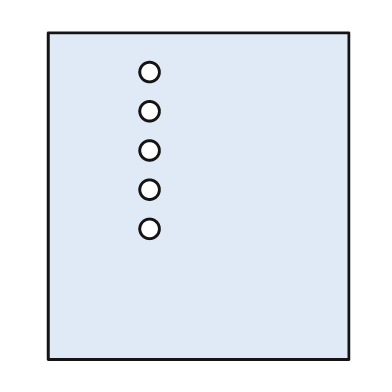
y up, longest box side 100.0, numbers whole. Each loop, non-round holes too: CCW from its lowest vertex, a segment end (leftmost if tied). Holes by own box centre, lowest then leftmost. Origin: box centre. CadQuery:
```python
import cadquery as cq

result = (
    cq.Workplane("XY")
    .moveTo(-46.0, -50.0)
    .lineTo(46.0, -50.0)
    .lineTo(46.0, 50.0)
    .lineTo(-46.0, 50.0)
    .close()
    .moveTo(-15.0, -10.0)
    .circle(3.0)
    .moveTo(-15.0, 2.0)
    .circle(3.0)
    .moveTo(-15.0, 14.0)
    .circle(3.0)
    .moveTo(-15.0, 26.0)
    .circle(3.0)
    .moveTo(-15.0, 38.0)
    .circle(3.0)
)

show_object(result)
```